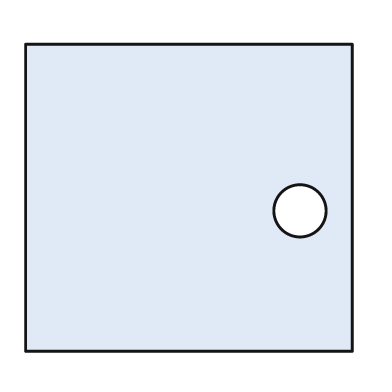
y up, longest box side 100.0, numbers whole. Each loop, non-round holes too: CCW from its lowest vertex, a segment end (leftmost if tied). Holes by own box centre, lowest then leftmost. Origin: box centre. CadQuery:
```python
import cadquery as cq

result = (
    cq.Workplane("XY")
    .moveTo(-50.0, -47.0)
    .lineTo(50.0, -47.0)
    .lineTo(50.0, 47.0)
    .lineTo(-50.0, 47.0)
    .close()
    .moveTo(34.0, -4.0)
    .circle(8.0)
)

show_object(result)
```